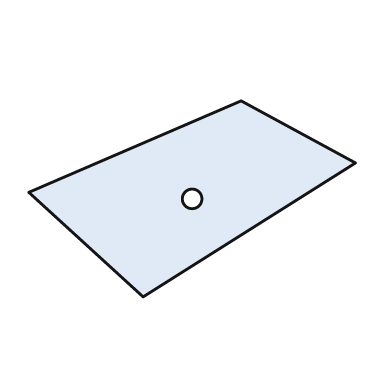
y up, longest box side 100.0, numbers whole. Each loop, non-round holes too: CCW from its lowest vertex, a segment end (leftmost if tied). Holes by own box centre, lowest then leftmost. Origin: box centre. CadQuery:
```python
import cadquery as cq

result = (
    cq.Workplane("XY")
    .moveTo(-15.0, -30.0)
    .lineTo(50.0, 11.0)
    .lineTo(15.0, 30.0)
    .lineTo(-50.0, 2.0)
    .close()
    .moveTo(0.0, 0.0)
    .circle(3.0)
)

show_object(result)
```